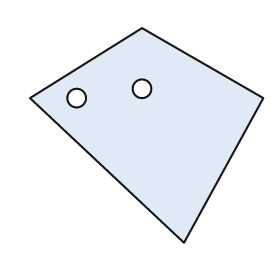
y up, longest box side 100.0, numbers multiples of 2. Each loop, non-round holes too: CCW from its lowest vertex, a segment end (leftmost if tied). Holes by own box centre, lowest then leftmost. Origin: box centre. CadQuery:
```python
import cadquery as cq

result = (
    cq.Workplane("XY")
    .moveTo(16.0, -46.0)
    .lineTo(50.0, 16.0)
    .lineTo(-2.0, 46.0)
    .lineTo(-50.0, 16.0)
    .close()
    .moveTo(-30.0, 16.0)
    .circle(4.0)
    .moveTo(-2.0, 20.0)
    .circle(4.0)
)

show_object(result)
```